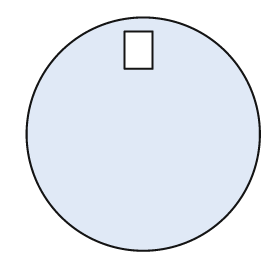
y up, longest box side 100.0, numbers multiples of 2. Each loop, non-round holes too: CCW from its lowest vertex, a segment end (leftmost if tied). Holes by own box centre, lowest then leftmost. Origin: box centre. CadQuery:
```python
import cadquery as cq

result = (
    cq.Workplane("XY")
    .moveTo(0.0, 0.0)
    .circle(50.0)
    .moveTo(-8.0, 28.0)
    .lineTo(4.0, 28.0)
    .lineTo(4.0, 44.0)
    .lineTo(-8.0, 44.0)
    .close()
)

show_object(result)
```